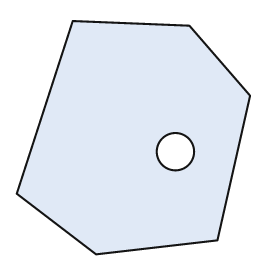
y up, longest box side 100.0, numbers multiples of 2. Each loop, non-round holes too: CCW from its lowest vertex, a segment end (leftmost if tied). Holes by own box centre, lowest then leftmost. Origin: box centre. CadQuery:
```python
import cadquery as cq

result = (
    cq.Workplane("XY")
    .moveTo(-16.0, -50.0)
    .lineTo(36.0, -44.0)
    .lineTo(50.0, 18.0)
    .lineTo(24.0, 48.0)
    .lineTo(-26.0, 50.0)
    .lineTo(-50.0, -24.0)
    .close()
    .moveTo(18.0, -6.0)
    .circle(8.0)
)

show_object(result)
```